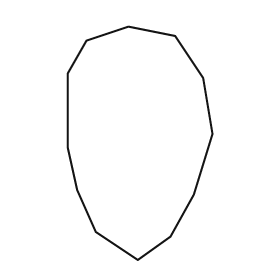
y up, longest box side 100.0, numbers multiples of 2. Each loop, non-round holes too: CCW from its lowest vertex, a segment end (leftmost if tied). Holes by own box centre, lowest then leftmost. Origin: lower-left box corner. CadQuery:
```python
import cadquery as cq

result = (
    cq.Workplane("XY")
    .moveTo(30.0, 0.0)
    .lineTo(44.0, 10.0)
    .lineTo(54.0, 28.0)
    .lineTo(62.0, 54.0)
    .lineTo(58.0, 78.0)
    .lineTo(46.0, 96.0)
    .lineTo(26.0, 100.0)
    .lineTo(8.0, 94.0)
    .lineTo(0.0, 80.0)
    .lineTo(0.0, 48.0)
    .lineTo(4.0, 30.0)
    .lineTo(12.0, 12.0)
    .close()
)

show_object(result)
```